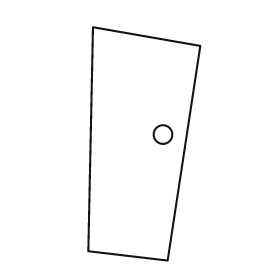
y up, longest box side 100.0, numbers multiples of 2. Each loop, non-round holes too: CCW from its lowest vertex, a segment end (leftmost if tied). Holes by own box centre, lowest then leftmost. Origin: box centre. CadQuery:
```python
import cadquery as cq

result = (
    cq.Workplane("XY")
    .moveTo(10.0, -50.0)
    .lineTo(24.0, 42.0)
    .lineTo(-22.0, 50.0)
    .lineTo(-24.0, -46.0)
    .close()
    .moveTo(8.0, 4.0)
    .circle(4.0)
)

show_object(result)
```